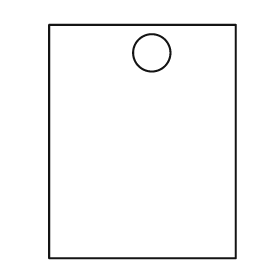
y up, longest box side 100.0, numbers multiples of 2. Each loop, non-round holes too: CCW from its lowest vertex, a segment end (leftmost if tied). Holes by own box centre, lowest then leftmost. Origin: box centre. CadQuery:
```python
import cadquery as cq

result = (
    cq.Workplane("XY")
    .moveTo(-40.0, -50.0)
    .lineTo(40.0, -50.0)
    .lineTo(40.0, 50.0)
    .lineTo(-40.0, 50.0)
    .close()
    .moveTo(4.0, 38.0)
    .circle(8.0)
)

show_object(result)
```